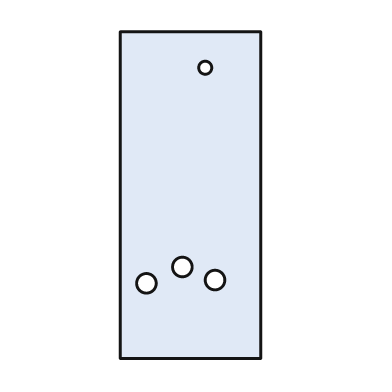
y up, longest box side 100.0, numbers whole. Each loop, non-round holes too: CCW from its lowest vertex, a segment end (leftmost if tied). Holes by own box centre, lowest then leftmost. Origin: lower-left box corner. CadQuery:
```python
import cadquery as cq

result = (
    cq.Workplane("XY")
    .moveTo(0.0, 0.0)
    .lineTo(43.0, 0.0)
    .lineTo(43.0, 100.0)
    .lineTo(0.0, 100.0)
    .close()
    .moveTo(8.0, 23.0)
    .circle(3.0)
    .moveTo(29.0, 24.0)
    .circle(3.0)
    .moveTo(19.0, 28.0)
    .circle(3.0)
    .moveTo(26.0, 89.0)
    .circle(2.0)
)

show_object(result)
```